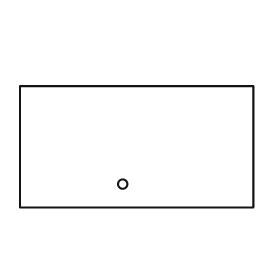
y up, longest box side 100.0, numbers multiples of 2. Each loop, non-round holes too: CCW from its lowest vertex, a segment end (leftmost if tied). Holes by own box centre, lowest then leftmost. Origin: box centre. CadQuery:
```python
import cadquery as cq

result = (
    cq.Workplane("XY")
    .moveTo(-50.0, -26.0)
    .lineTo(50.0, -26.0)
    .lineTo(50.0, 26.0)
    .lineTo(-50.0, 26.0)
    .close()
    .moveTo(-6.0, -16.0)
    .circle(2.0)
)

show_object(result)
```